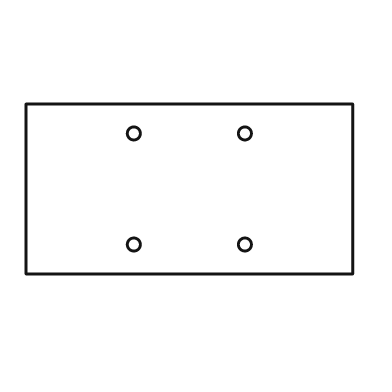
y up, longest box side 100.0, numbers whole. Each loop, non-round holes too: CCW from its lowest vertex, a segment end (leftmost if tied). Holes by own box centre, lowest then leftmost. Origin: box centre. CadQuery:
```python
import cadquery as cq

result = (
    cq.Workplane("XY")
    .moveTo(-50.0, -26.0)
    .lineTo(50.0, -26.0)
    .lineTo(50.0, 26.0)
    .lineTo(-50.0, 26.0)
    .close()
    .moveTo(-17.0, -17.0)
    .circle(2.0)
    .moveTo(17.0, -17.0)
    .circle(2.0)
    .moveTo(-17.0, 17.0)
    .circle(2.0)
    .moveTo(17.0, 17.0)
    .circle(2.0)
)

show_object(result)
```